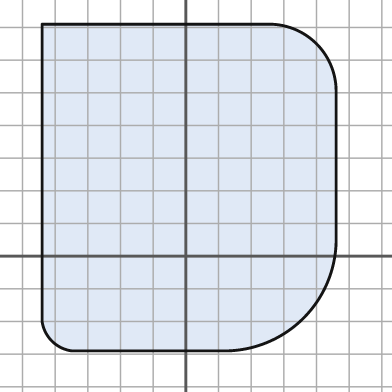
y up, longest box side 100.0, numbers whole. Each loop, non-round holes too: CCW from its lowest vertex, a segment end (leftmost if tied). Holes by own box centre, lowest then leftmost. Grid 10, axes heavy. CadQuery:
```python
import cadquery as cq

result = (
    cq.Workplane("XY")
    .moveTo(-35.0, -29.0)
    .lineTo(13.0, -29.0)
    .threePointArc((36.0, -19.0), (46.0, 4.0))
    .lineTo(46.0, 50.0)
    .threePointArc((40.0, 65.0), (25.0, 71.0))
    .lineTo(-44.0, 71.0)
    .lineTo(-44.0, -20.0)
    .threePointArc((-41.0, -26.0), (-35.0, -29.0))
    .close()
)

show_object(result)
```